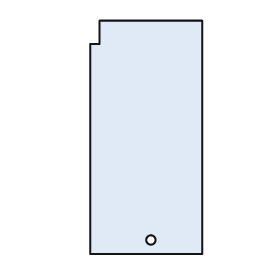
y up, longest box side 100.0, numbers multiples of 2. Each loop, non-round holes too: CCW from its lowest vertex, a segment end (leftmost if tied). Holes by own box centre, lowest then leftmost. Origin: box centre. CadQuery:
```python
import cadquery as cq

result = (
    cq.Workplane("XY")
    .moveTo(-24.0, -50.0)
    .lineTo(24.0, -50.0)
    .lineTo(24.0, 50.0)
    .lineTo(-20.0, 50.0)
    .lineTo(-20.0, 40.0)
    .lineTo(-24.0, 40.0)
    .close()
    .moveTo(2.0, -44.0)
    .circle(2.0)
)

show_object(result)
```